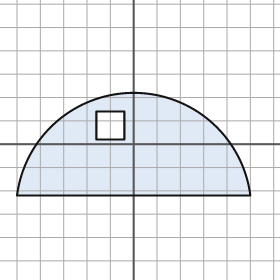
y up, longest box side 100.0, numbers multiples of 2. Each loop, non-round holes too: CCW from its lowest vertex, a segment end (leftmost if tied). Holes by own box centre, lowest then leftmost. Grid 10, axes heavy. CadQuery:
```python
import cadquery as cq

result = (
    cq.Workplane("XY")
    .moveTo(-50.0, -22.0)
    .lineTo(50.0, -22.0)
    .threePointArc((0.0, 22.0), (-50.0, -22.0))
    .close()
    .moveTo(-16.0, 2.0)
    .lineTo(-4.0, 2.0)
    .lineTo(-4.0, 14.0)
    .lineTo(-16.0, 14.0)
    .close()
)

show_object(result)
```